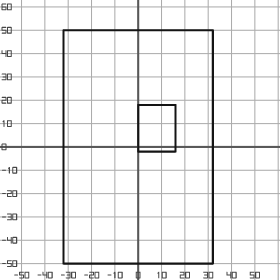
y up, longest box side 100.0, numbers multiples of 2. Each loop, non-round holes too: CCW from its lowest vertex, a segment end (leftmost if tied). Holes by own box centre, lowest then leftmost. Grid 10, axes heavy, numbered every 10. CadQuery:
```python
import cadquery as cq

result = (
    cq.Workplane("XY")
    .moveTo(-32.0, -50.0)
    .lineTo(32.0, -50.0)
    .lineTo(32.0, 50.0)
    .lineTo(-32.0, 50.0)
    .close()
    .moveTo(0.0, -2.0)
    .lineTo(16.0, -2.0)
    .lineTo(16.0, 18.0)
    .lineTo(0.0, 18.0)
    .close()
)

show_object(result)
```